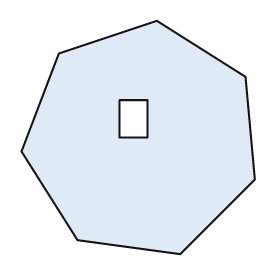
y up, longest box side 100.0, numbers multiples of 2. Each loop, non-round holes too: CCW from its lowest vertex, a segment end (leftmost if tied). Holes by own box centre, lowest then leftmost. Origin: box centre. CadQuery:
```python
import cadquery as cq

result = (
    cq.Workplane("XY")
    .moveTo(18.0, -50.0)
    .lineTo(50.0, -18.0)
    .lineTo(46.0, 26.0)
    .lineTo(8.0, 50.0)
    .lineTo(-34.0, 36.0)
    .lineTo(-50.0, -6.0)
    .lineTo(-26.0, -44.0)
    .close()
    .moveTo(-8.0, 0.0)
    .lineTo(4.0, 0.0)
    .lineTo(4.0, 16.0)
    .lineTo(-8.0, 16.0)
    .close()
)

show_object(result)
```